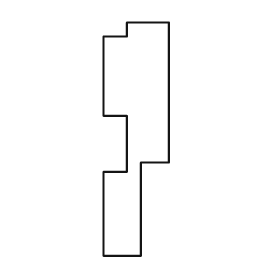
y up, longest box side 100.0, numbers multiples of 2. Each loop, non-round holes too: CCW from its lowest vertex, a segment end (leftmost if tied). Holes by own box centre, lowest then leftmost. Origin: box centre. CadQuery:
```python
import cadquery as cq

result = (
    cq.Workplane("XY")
    .moveTo(-14.0, -50.0)
    .lineTo(2.0, -50.0)
    .lineTo(2.0, -10.0)
    .lineTo(14.0, -10.0)
    .lineTo(14.0, 50.0)
    .lineTo(-4.0, 50.0)
    .lineTo(-4.0, 44.0)
    .lineTo(-14.0, 44.0)
    .lineTo(-14.0, 10.0)
    .lineTo(-4.0, 10.0)
    .lineTo(-4.0, -14.0)
    .lineTo(-14.0, -14.0)
    .close()
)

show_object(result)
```